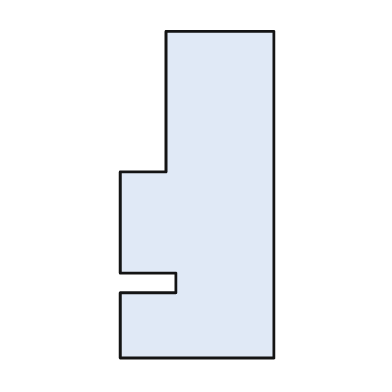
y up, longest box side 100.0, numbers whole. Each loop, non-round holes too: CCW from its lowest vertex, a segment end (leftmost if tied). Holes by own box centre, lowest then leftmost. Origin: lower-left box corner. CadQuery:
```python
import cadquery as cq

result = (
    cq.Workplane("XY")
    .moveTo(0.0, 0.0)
    .lineTo(47.0, 0.0)
    .lineTo(47.0, 100.0)
    .lineTo(14.0, 100.0)
    .lineTo(14.0, 57.0)
    .lineTo(0.0, 57.0)
    .lineTo(0.0, 26.0)
    .lineTo(17.0, 26.0)
    .lineTo(17.0, 20.0)
    .lineTo(0.0, 20.0)
    .close()
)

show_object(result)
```